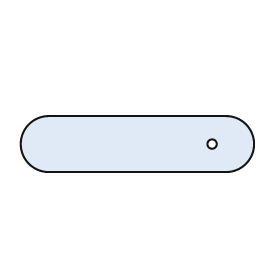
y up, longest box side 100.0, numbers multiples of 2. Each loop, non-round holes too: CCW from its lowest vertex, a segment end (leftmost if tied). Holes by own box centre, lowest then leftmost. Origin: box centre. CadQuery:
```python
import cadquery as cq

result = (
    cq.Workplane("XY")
    .moveTo(-38.0, -12.0)
    .lineTo(38.0, -12.0)
    .threePointArc((50.0, 0.0), (38.0, 12.0))
    .lineTo(-38.0, 12.0)
    .threePointArc((-50.0, 0.0), (-38.0, -12.0))
    .close()
    .moveTo(32.0, 0.0)
    .circle(2.0)
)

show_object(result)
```